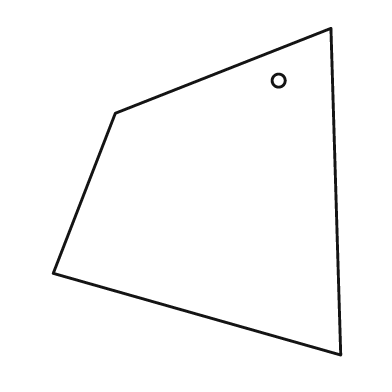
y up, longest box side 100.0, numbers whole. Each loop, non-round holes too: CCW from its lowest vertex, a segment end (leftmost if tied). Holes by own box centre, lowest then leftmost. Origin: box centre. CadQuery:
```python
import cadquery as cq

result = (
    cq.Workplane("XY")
    .moveTo(44.0, -50.0)
    .lineTo(41.0, 50.0)
    .lineTo(-25.0, 24.0)
    .lineTo(-44.0, -25.0)
    .close()
    .moveTo(25.0, 34.0)
    .circle(2.0)
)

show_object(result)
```